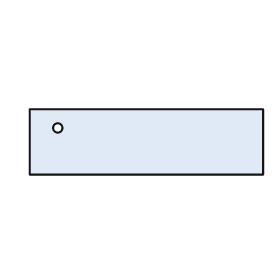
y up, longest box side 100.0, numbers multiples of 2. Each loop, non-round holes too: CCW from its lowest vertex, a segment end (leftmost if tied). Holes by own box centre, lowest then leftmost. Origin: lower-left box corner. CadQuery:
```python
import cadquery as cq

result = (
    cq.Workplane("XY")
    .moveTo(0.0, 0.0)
    .lineTo(100.0, 0.0)
    .lineTo(100.0, 28.0)
    .lineTo(0.0, 28.0)
    .close()
    .moveTo(12.0, 20.0)
    .circle(2.0)
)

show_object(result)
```